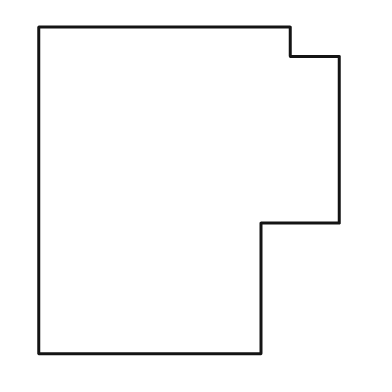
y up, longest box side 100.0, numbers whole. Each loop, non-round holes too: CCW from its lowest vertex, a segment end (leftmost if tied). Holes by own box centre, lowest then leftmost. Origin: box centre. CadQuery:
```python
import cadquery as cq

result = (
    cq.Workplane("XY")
    .moveTo(-46.0, -50.0)
    .lineTo(22.0, -50.0)
    .lineTo(22.0, -10.0)
    .lineTo(46.0, -10.0)
    .lineTo(46.0, 41.0)
    .lineTo(31.0, 41.0)
    .lineTo(31.0, 50.0)
    .lineTo(-46.0, 50.0)
    .close()
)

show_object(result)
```